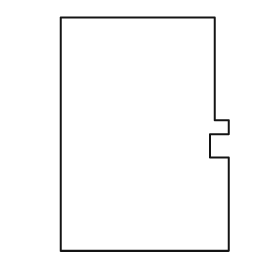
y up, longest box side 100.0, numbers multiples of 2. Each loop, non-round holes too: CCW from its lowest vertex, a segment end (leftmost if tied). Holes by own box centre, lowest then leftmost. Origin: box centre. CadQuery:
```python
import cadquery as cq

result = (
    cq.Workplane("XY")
    .moveTo(-36.0, -50.0)
    .lineTo(36.0, -50.0)
    .lineTo(36.0, -10.0)
    .lineTo(28.0, -10.0)
    .lineTo(28.0, 0.0)
    .lineTo(36.0, 0.0)
    .lineTo(36.0, 6.0)
    .lineTo(30.0, 6.0)
    .lineTo(30.0, 50.0)
    .lineTo(-36.0, 50.0)
    .close()
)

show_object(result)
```